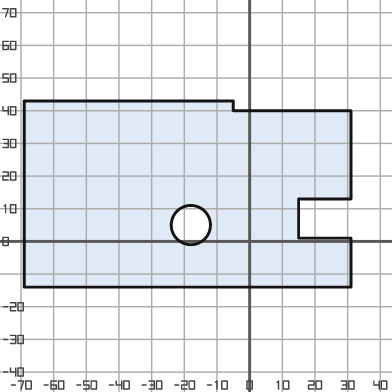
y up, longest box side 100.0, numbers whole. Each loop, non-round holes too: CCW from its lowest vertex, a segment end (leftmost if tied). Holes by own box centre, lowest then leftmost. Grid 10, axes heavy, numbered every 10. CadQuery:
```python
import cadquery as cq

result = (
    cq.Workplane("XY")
    .moveTo(-69.0, -14.0)
    .lineTo(31.0, -14.0)
    .lineTo(31.0, 1.0)
    .lineTo(15.0, 1.0)
    .lineTo(15.0, 13.0)
    .lineTo(31.0, 13.0)
    .lineTo(31.0, 40.0)
    .lineTo(-5.0, 40.0)
    .lineTo(-5.0, 43.0)
    .lineTo(-69.0, 43.0)
    .close()
    .moveTo(-18.0, 5.0)
    .circle(6.0)
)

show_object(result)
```